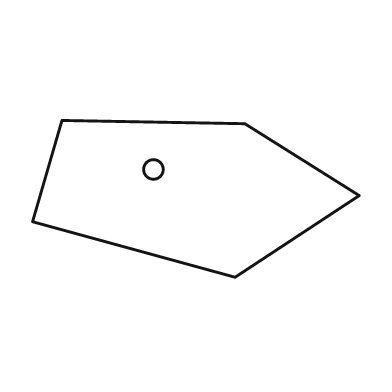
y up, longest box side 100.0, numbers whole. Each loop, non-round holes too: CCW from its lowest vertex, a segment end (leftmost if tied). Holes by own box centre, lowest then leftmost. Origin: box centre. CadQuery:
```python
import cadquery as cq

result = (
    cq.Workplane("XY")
    .moveTo(12.0, -24.0)
    .lineTo(50.0, 1.0)
    .lineTo(15.0, 23.0)
    .lineTo(-41.0, 24.0)
    .lineTo(-50.0, -7.0)
    .close()
    .moveTo(-13.0, 9.0)
    .circle(3.0)
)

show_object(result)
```